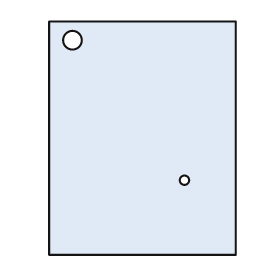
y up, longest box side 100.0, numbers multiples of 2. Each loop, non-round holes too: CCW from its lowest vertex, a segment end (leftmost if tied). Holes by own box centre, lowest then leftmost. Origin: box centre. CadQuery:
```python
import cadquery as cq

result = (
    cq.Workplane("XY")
    .moveTo(-40.0, -50.0)
    .lineTo(40.0, -50.0)
    .lineTo(40.0, 50.0)
    .lineTo(-40.0, 50.0)
    .close()
    .moveTo(18.0, -18.0)
    .circle(2.0)
    .moveTo(-30.0, 42.0)
    .circle(4.0)
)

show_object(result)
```